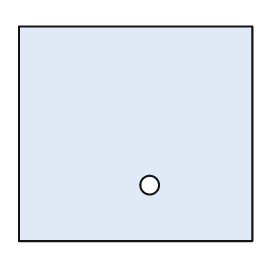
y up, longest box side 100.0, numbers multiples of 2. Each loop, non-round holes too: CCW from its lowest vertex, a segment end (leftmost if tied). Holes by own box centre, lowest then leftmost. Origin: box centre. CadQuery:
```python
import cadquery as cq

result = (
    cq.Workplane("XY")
    .moveTo(-50.0, -46.0)
    .lineTo(50.0, -46.0)
    .lineTo(50.0, 46.0)
    .lineTo(-50.0, 46.0)
    .close()
    .moveTo(6.0, -22.0)
    .circle(4.0)
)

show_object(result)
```